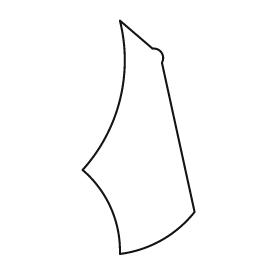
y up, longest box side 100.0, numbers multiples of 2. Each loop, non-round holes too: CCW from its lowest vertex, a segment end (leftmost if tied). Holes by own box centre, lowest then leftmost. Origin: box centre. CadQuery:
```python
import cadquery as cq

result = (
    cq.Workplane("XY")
    .moveTo(-8.0, -50.0)
    .threePointArc((10.0, -44.0), (24.0, -32.0))
    .lineTo(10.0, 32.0)
    .threePointArc((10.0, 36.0), (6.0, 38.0))
    .lineTo(-8.0, 50.0)
    .threePointArc((-8.0, 16.0), (-24.0, -14.0))
    .threePointArc((-12.0, -30.0), (-8.0, -50.0))
    .close()
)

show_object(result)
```